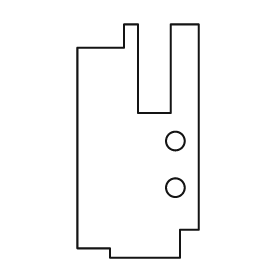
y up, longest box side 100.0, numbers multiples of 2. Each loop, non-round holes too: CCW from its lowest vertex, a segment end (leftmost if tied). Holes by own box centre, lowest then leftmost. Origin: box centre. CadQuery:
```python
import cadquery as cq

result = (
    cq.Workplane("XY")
    .moveTo(-12.0, -50.0)
    .lineTo(18.0, -50.0)
    .lineTo(18.0, -38.0)
    .lineTo(26.0, -38.0)
    .lineTo(26.0, 50.0)
    .lineTo(14.0, 50.0)
    .lineTo(14.0, 12.0)
    .lineTo(0.0, 12.0)
    .lineTo(0.0, 50.0)
    .lineTo(-6.0, 50.0)
    .lineTo(-6.0, 40.0)
    .lineTo(-26.0, 40.0)
    .lineTo(-26.0, -46.0)
    .lineTo(-12.0, -46.0)
    .close()
    .moveTo(16.0, -20.0)
    .circle(4.0)
    .moveTo(16.0, 0.0)
    .circle(4.0)
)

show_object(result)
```